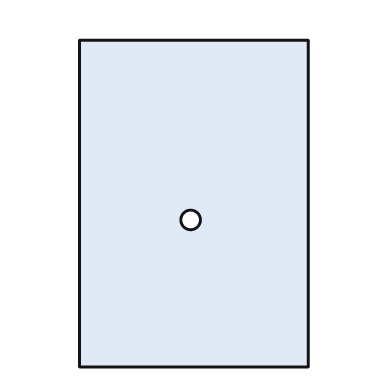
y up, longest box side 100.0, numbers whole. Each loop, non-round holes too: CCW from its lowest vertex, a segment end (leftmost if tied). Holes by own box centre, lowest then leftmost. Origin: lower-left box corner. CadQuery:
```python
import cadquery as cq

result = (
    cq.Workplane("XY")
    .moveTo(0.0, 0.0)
    .lineTo(70.0, 0.0)
    .lineTo(70.0, 100.0)
    .lineTo(0.0, 100.0)
    .close()
    .moveTo(34.0, 45.0)
    .circle(3.0)
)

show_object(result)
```